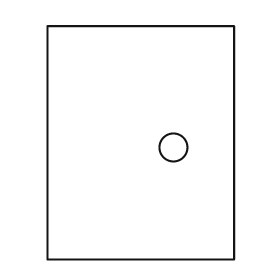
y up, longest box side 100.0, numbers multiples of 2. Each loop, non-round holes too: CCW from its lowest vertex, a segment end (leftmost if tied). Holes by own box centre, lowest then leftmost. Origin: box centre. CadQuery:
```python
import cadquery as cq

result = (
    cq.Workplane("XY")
    .moveTo(-40.0, -50.0)
    .lineTo(40.0, -50.0)
    .lineTo(40.0, 50.0)
    .lineTo(-40.0, 50.0)
    .close()
    .moveTo(14.0, -2.0)
    .circle(6.0)
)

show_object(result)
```